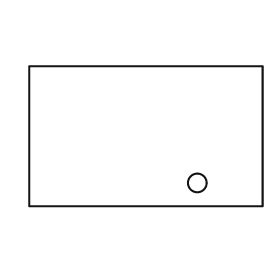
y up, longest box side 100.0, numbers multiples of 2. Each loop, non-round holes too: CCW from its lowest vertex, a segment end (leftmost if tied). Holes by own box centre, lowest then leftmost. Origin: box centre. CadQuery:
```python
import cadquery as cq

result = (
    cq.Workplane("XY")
    .moveTo(-50.0, -30.0)
    .lineTo(50.0, -30.0)
    .lineTo(50.0, 30.0)
    .lineTo(-50.0, 30.0)
    .close()
    .moveTo(22.0, -20.0)
    .circle(4.0)
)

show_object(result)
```